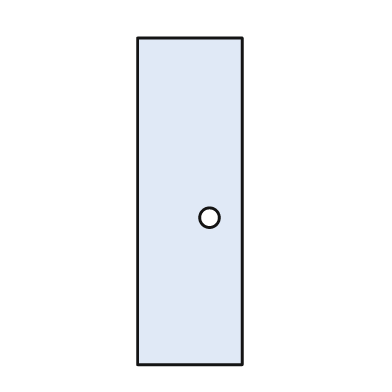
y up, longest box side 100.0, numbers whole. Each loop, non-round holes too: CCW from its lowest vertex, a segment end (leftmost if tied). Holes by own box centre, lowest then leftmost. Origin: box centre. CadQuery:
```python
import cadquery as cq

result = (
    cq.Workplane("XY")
    .moveTo(-16.0, -50.0)
    .lineTo(16.0, -50.0)
    .lineTo(16.0, 50.0)
    .lineTo(-16.0, 50.0)
    .close()
    .moveTo(6.0, -5.0)
    .circle(3.0)
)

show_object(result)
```